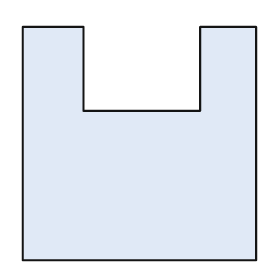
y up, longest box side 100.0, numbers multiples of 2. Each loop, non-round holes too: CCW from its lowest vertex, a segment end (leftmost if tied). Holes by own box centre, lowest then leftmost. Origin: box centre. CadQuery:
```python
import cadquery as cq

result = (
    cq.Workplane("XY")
    .moveTo(-50.0, -50.0)
    .lineTo(50.0, -50.0)
    .lineTo(50.0, 50.0)
    .lineTo(26.0, 50.0)
    .lineTo(26.0, 14.0)
    .lineTo(-24.0, 14.0)
    .lineTo(-24.0, 50.0)
    .lineTo(-50.0, 50.0)
    .close()
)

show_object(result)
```